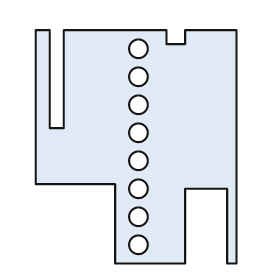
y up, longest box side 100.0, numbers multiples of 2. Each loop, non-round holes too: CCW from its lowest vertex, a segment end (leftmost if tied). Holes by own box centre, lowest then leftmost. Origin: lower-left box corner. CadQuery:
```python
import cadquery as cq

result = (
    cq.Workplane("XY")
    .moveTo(34.0, 0.0)
    .lineTo(64.0, 0.0)
    .lineTo(64.0, 32.0)
    .lineTo(82.0, 32.0)
    .lineTo(82.0, 0.0)
    .lineTo(86.0, 0.0)
    .lineTo(86.0, 100.0)
    .lineTo(64.0, 100.0)
    .lineTo(64.0, 94.0)
    .lineTo(56.0, 94.0)
    .lineTo(56.0, 100.0)
    .lineTo(12.0, 100.0)
    .lineTo(12.0, 58.0)
    .lineTo(6.0, 58.0)
    .lineTo(6.0, 100.0)
    .lineTo(0.0, 100.0)
    .lineTo(0.0, 34.0)
    .lineTo(34.0, 34.0)
    .close()
    .moveTo(44.0, 8.0)
    .circle(4.0)
    .moveTo(44.0, 20.0)
    .circle(4.0)
    .moveTo(44.0, 32.0)
    .circle(4.0)
    .moveTo(44.0, 44.0)
    .circle(4.0)
    .moveTo(44.0, 56.0)
    .circle(4.0)
    .moveTo(44.0, 68.0)
    .circle(4.0)
    .moveTo(44.0, 80.0)
    .circle(4.0)
    .moveTo(44.0, 92.0)
    .circle(4.0)
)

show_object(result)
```